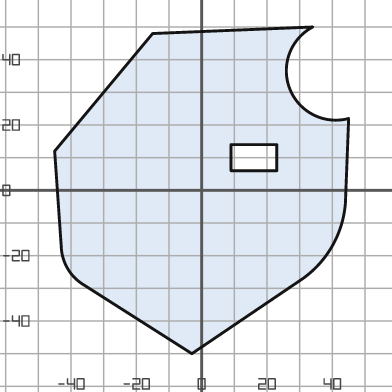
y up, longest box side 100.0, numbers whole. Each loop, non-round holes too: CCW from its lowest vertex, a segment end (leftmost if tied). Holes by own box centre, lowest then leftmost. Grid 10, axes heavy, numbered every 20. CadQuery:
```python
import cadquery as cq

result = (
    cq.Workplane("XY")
    .moveTo(-3.0, -50.0)
    .lineTo(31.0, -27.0)
    .threePointArc((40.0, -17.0), (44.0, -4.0))
    .lineTo(45.0, 22.0)
    .threePointArc((27.0, 31.0), (34.0, 50.0))
    .lineTo(-15.0, 48.0)
    .lineTo(-45.0, 12.0)
    .lineTo(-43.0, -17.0)
    .threePointArc((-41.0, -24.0), (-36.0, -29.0))
    .close()
    .moveTo(9.0, 6.0)
    .lineTo(23.0, 6.0)
    .lineTo(23.0, 14.0)
    .lineTo(9.0, 14.0)
    .close()
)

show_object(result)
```